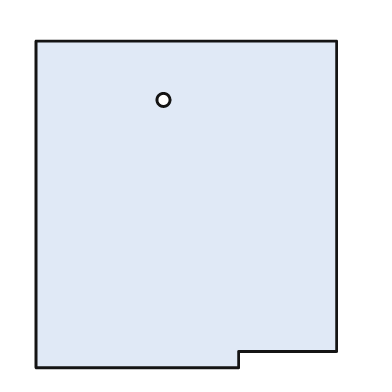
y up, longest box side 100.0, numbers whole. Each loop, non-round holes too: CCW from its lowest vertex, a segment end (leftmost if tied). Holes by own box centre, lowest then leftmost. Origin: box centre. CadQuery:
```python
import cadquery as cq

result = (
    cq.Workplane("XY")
    .moveTo(-46.0, -50.0)
    .lineTo(16.0, -50.0)
    .lineTo(16.0, -45.0)
    .lineTo(46.0, -45.0)
    .lineTo(46.0, 50.0)
    .lineTo(-46.0, 50.0)
    .close()
    .moveTo(-7.0, 32.0)
    .circle(2.0)
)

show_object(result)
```